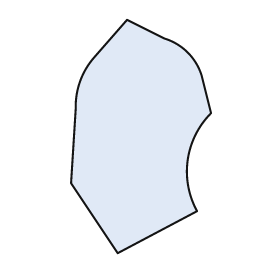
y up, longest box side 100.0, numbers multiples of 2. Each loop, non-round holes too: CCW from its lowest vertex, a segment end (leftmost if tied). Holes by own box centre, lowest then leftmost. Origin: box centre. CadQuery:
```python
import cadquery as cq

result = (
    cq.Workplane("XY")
    .moveTo(-10.0, -50.0)
    .lineTo(24.0, -32.0)
    .threePointArc((20.0, -10.0), (30.0, 10.0))
    .lineTo(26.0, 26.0)
    .threePointArc((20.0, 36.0), (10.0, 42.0))
    .lineTo(-6.0, 50.0)
    .lineTo(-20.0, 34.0)
    .threePointArc((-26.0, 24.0), (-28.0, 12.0))
    .lineTo(-30.0, -20.0)
    .close()
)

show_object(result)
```